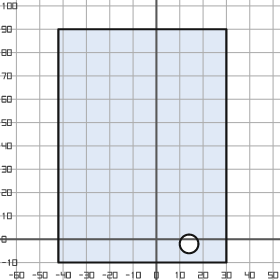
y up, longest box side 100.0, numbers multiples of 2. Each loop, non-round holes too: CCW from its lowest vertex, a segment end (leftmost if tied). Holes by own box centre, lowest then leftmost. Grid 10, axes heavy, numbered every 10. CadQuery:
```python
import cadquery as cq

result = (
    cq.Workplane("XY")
    .moveTo(-42.0, -10.0)
    .lineTo(30.0, -10.0)
    .lineTo(30.0, 90.0)
    .lineTo(-42.0, 90.0)
    .close()
    .moveTo(14.0, -2.0)
    .circle(4.0)
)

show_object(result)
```